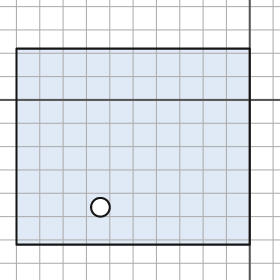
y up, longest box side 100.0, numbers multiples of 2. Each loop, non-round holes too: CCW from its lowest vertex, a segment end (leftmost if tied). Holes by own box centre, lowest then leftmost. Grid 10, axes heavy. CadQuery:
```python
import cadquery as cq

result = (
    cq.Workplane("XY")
    .moveTo(-100.0, -62.0)
    .lineTo(0.0, -62.0)
    .lineTo(0.0, 22.0)
    .lineTo(-100.0, 22.0)
    .close()
    .moveTo(-64.0, -46.0)
    .circle(4.0)
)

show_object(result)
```